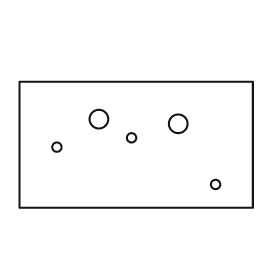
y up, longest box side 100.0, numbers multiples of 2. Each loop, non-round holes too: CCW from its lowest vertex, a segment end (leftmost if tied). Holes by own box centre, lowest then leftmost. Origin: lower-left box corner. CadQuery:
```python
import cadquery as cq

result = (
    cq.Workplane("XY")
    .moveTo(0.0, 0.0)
    .lineTo(100.0, 0.0)
    .lineTo(100.0, 54.0)
    .lineTo(0.0, 54.0)
    .close()
    .moveTo(84.0, 10.0)
    .circle(2.0)
    .moveTo(16.0, 26.0)
    .circle(2.0)
    .moveTo(48.0, 30.0)
    .circle(2.0)
    .moveTo(68.0, 36.0)
    .circle(4.0)
    .moveTo(34.0, 38.0)
    .circle(4.0)
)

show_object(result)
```